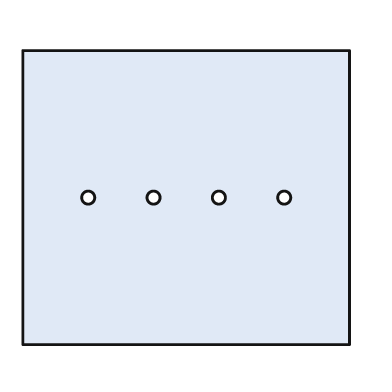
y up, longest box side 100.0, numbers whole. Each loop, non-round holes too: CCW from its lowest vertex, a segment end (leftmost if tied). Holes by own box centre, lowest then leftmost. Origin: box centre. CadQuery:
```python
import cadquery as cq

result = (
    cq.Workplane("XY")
    .moveTo(-50.0, -45.0)
    .lineTo(50.0, -45.0)
    .lineTo(50.0, 45.0)
    .lineTo(-50.0, 45.0)
    .close()
    .moveTo(-30.0, 0.0)
    .circle(2.0)
    .moveTo(-10.0, 0.0)
    .circle(2.0)
    .moveTo(10.0, 0.0)
    .circle(2.0)
    .moveTo(30.0, 0.0)
    .circle(2.0)
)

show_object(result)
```